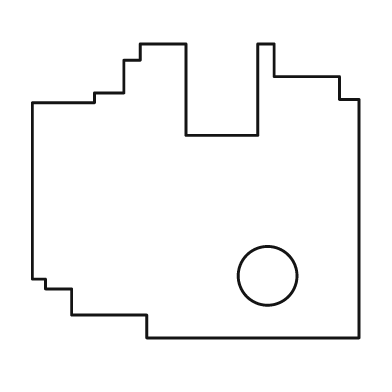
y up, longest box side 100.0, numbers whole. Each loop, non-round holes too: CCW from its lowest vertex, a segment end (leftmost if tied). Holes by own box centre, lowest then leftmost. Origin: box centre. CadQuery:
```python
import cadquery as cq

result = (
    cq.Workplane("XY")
    .moveTo(-15.0, -45.0)
    .lineTo(50.0, -45.0)
    .lineTo(50.0, 28.0)
    .lineTo(44.0, 28.0)
    .lineTo(44.0, 35.0)
    .lineTo(24.0, 35.0)
    .lineTo(24.0, 45.0)
    .lineTo(19.0, 45.0)
    .lineTo(19.0, 17.0)
    .lineTo(-3.0, 17.0)
    .lineTo(-3.0, 45.0)
    .lineTo(-17.0, 45.0)
    .lineTo(-17.0, 40.0)
    .lineTo(-22.0, 40.0)
    .lineTo(-22.0, 30.0)
    .lineTo(-31.0, 30.0)
    .lineTo(-31.0, 27.0)
    .lineTo(-50.0, 27.0)
    .lineTo(-50.0, -27.0)
    .lineTo(-46.0, -27.0)
    .lineTo(-46.0, -30.0)
    .lineTo(-38.0, -30.0)
    .lineTo(-38.0, -38.0)
    .lineTo(-15.0, -38.0)
    .close()
    .moveTo(22.0, -26.0)
    .circle(9.0)
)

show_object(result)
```